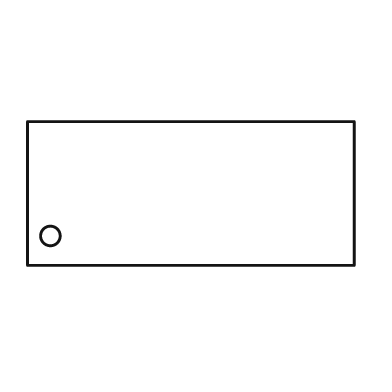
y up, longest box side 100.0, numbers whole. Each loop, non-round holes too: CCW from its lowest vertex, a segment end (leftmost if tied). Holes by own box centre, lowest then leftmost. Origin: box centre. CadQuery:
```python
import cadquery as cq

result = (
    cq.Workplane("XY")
    .moveTo(-50.0, -22.0)
    .lineTo(50.0, -22.0)
    .lineTo(50.0, 22.0)
    .lineTo(-50.0, 22.0)
    .close()
    .moveTo(-43.0, -13.0)
    .circle(3.0)
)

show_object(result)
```